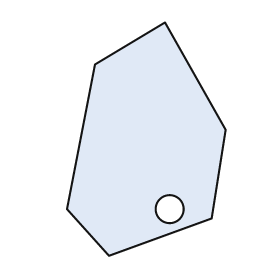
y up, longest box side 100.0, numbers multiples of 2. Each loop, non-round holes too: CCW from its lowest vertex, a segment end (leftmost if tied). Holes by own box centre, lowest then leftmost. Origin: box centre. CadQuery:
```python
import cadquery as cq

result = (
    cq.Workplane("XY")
    .moveTo(-16.0, -50.0)
    .lineTo(28.0, -34.0)
    .lineTo(34.0, 4.0)
    .lineTo(8.0, 50.0)
    .lineTo(-22.0, 32.0)
    .lineTo(-34.0, -30.0)
    .close()
    .moveTo(10.0, -30.0)
    .circle(6.0)
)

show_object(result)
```